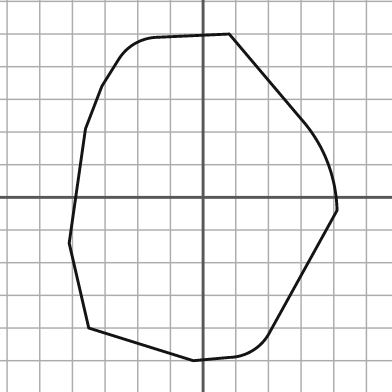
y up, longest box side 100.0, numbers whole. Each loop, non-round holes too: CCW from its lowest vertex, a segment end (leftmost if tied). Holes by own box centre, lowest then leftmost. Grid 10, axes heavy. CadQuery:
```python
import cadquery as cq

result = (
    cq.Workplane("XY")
    .moveTo(-3.0, -50.0)
    .lineTo(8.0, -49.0)
    .threePointArc((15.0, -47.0), (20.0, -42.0))
    .lineTo(41.0, -4.0)
    .threePointArc((38.0, 11.0), (30.0, 24.0))
    .lineTo(8.0, 50.0)
    .lineTo(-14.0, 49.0)
    .threePointArc((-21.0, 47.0), (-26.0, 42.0))
    .lineTo(-31.0, 34.0)
    .lineTo(-36.0, 21.0)
    .lineTo(-41.0, -14.0)
    .lineTo(-35.0, -40.0)
    .close()
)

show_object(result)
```